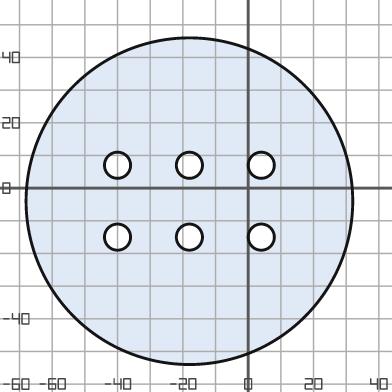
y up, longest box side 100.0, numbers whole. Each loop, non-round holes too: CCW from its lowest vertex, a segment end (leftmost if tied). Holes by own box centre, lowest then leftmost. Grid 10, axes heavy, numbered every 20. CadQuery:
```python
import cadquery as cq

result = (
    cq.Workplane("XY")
    .moveTo(-18.0, -4.0)
    .circle(50.0)
    .moveTo(-40.0, -15.0)
    .circle(4.0)
    .moveTo(-18.0, -15.0)
    .circle(4.0)
    .moveTo(4.0, -15.0)
    .circle(4.0)
    .moveTo(-40.0, 7.0)
    .circle(4.0)
    .moveTo(-18.0, 7.0)
    .circle(4.0)
    .moveTo(4.0, 7.0)
    .circle(4.0)
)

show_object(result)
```